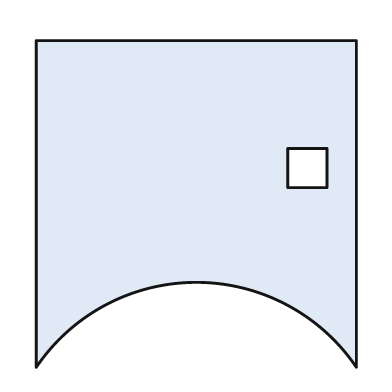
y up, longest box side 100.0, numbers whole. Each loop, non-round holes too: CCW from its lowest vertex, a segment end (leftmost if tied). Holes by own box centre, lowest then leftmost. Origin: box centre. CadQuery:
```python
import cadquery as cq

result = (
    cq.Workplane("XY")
    .moveTo(-49.0, -50.0)
    .threePointArc((0.0, -24.0), (49.0, -50.0))
    .lineTo(49.0, 50.0)
    .lineTo(-49.0, 50.0)
    .close()
    .moveTo(28.0, 5.0)
    .lineTo(40.0, 5.0)
    .lineTo(40.0, 17.0)
    .lineTo(28.0, 17.0)
    .close()
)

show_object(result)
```